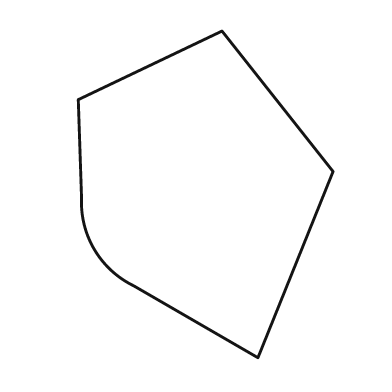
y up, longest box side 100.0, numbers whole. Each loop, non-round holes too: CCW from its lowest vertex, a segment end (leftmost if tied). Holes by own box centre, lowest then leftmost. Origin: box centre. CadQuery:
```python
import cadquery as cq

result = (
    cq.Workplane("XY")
    .moveTo(16.0, -50.0)
    .lineTo(39.0, 7.0)
    .lineTo(5.0, 50.0)
    .lineTo(-39.0, 29.0)
    .lineTo(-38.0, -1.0)
    .threePointArc((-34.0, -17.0), (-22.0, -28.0))
    .close()
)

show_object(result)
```